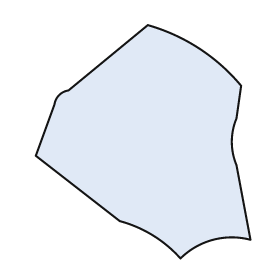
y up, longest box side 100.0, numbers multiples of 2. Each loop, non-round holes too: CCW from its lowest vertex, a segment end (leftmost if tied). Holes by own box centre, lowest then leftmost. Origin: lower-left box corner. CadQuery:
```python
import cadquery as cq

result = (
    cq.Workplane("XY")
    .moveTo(62.0, 0.0)
    .threePointArc((76.0, 8.0), (92.0, 8.0))
    .lineTo(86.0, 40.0)
    .threePointArc((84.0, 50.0), (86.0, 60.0))
    .lineTo(88.0, 74.0)
    .threePointArc((70.0, 90.0), (48.0, 100.0))
    .lineTo(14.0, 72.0)
    .threePointArc((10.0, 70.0), (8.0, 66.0))
    .lineTo(0.0, 44.0)
    .lineTo(36.0, 16.0)
    .threePointArc((50.0, 10.0), (62.0, 0.0))
    .close()
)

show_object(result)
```